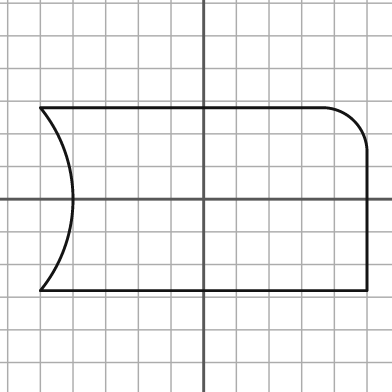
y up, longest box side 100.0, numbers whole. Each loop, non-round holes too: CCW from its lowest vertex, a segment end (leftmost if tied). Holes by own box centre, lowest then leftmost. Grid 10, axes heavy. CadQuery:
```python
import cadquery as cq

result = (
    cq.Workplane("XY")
    .moveTo(-50.0, -28.0)
    .lineTo(50.0, -28.0)
    .lineTo(50.0, 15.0)
    .threePointArc((46.0, 24.0), (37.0, 28.0))
    .lineTo(-50.0, 28.0)
    .threePointArc((-40.0, 0.0), (-50.0, -28.0))
    .close()
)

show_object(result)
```